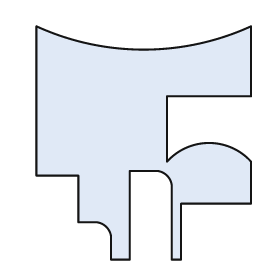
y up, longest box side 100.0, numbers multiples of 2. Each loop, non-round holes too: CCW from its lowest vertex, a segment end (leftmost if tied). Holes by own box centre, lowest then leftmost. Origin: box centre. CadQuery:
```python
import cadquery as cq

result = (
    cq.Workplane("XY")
    .moveTo(-14.0, -50.0)
    .lineTo(-6.0, -50.0)
    .lineTo(-6.0, -12.0)
    .lineTo(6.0, -12.0)
    .threePointArc((10.0, -14.0), (12.0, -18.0))
    .lineTo(12.0, -50.0)
    .lineTo(16.0, -50.0)
    .lineTo(16.0, -26.0)
    .lineTo(46.0, -26.0)
    .lineTo(46.0, -8.0)
    .threePointArc((28.0, 0.0), (10.0, -8.0))
    .lineTo(10.0, 20.0)
    .lineTo(46.0, 20.0)
    .lineTo(46.0, 50.0)
    .threePointArc((0.0, 40.0), (-46.0, 50.0))
    .lineTo(-46.0, -14.0)
    .lineTo(-28.0, -14.0)
    .lineTo(-28.0, -34.0)
    .lineTo(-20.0, -34.0)
    .threePointArc((-16.0, -36.0), (-14.0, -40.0))
    .close()
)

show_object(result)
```